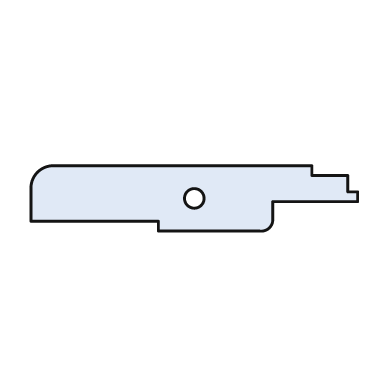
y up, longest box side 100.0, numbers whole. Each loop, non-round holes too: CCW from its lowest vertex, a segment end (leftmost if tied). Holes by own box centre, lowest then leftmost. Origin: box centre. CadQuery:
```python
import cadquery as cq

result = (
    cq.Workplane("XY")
    .moveTo(-11.0, -10.0)
    .lineTo(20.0, -10.0)
    .threePointArc((23.0, -9.0), (24.0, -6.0))
    .lineTo(24.0, -1.0)
    .lineTo(50.0, -1.0)
    .lineTo(50.0, 2.0)
    .lineTo(47.0, 2.0)
    .lineTo(47.0, 7.0)
    .lineTo(36.0, 7.0)
    .lineTo(36.0, 10.0)
    .lineTo(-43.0, 10.0)
    .threePointArc((-48.0, 8.0), (-50.0, 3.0))
    .lineTo(-50.0, -7.0)
    .lineTo(-11.0, -7.0)
    .close()
    .moveTo(0.0, 0.0)
    .circle(3.0)
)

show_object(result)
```